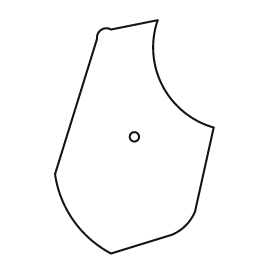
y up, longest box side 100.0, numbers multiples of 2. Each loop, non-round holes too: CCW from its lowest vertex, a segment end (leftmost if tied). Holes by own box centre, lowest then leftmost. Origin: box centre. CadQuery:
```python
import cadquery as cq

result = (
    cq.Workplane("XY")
    .moveTo(-10.0, -50.0)
    .lineTo(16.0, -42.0)
    .threePointArc((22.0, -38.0), (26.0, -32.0))
    .lineTo(34.0, 4.0)
    .threePointArc((12.0, 22.0), (10.0, 50.0))
    .lineTo(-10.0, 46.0)
    .threePointArc((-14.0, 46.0), (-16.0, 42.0))
    .lineTo(-34.0, -16.0)
    .threePointArc((-26.0, -36.0), (-10.0, -50.0))
    .close()
    .moveTo(0.0, 0.0)
    .circle(2.0)
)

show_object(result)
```